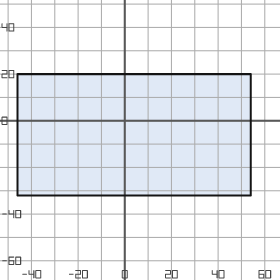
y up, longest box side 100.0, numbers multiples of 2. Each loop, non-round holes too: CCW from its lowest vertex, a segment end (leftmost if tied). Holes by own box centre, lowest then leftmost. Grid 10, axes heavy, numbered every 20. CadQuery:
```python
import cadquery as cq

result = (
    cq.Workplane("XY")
    .moveTo(-46.0, -32.0)
    .lineTo(54.0, -32.0)
    .lineTo(54.0, 20.0)
    .lineTo(-46.0, 20.0)
    .close()
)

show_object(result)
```